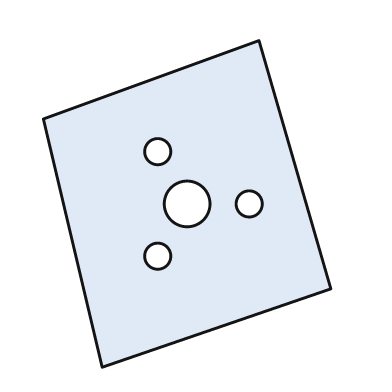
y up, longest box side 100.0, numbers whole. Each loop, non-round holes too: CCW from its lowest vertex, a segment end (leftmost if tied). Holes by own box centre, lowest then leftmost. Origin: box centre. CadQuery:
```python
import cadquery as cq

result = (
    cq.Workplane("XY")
    .moveTo(-26.0, -50.0)
    .lineTo(44.0, -26.0)
    .lineTo(22.0, 50.0)
    .lineTo(-44.0, 26.0)
    .close()
    .moveTo(-9.0, -16.0)
    .circle(4.0)
    .moveTo(0.0, 0.0)
    .circle(7.0)
    .moveTo(19.0, 0.0)
    .circle(4.0)
    .moveTo(-9.0, 16.0)
    .circle(4.0)
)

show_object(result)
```